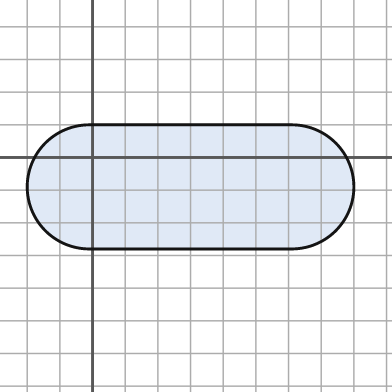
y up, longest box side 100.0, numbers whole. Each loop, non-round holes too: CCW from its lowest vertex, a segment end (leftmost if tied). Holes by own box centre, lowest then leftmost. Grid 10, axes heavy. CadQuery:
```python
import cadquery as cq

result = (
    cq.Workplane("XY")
    .moveTo(-1.0, -28.0)
    .lineTo(61.0, -28.0)
    .threePointArc((80.0, -9.0), (61.0, 10.0))
    .lineTo(-1.0, 10.0)
    .threePointArc((-20.0, -9.0), (-1.0, -28.0))
    .close()
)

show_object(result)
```